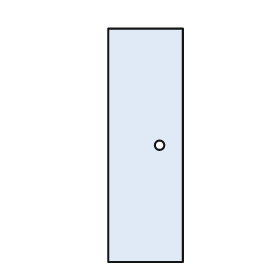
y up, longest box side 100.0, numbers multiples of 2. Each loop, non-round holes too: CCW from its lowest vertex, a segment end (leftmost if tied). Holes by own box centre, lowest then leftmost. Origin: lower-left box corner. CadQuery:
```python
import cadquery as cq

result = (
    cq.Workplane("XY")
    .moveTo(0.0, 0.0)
    .lineTo(32.0, 0.0)
    .lineTo(32.0, 100.0)
    .lineTo(0.0, 100.0)
    .close()
    .moveTo(22.0, 50.0)
    .circle(2.0)
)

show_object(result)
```